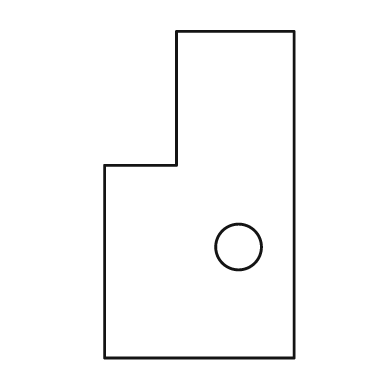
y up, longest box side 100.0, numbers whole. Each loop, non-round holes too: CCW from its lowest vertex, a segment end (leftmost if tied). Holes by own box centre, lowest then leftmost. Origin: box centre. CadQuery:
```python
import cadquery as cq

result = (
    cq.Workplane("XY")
    .moveTo(-29.0, -50.0)
    .lineTo(29.0, -50.0)
    .lineTo(29.0, 50.0)
    .lineTo(-7.0, 50.0)
    .lineTo(-7.0, 9.0)
    .lineTo(-29.0, 9.0)
    .close()
    .moveTo(12.0, -16.0)
    .circle(7.0)
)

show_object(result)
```